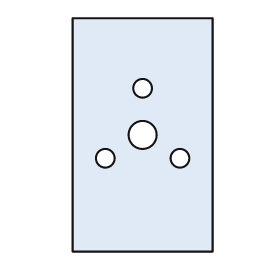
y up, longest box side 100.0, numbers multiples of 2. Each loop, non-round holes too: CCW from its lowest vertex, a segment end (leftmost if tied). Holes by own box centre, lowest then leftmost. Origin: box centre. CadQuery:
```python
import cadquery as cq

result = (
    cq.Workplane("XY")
    .moveTo(-30.0, -50.0)
    .lineTo(30.0, -50.0)
    .lineTo(30.0, 50.0)
    .lineTo(-30.0, 50.0)
    .close()
    .moveTo(-16.0, -10.0)
    .circle(4.0)
    .moveTo(16.0, -10.0)
    .circle(4.0)
    .moveTo(0.0, 0.0)
    .circle(6.0)
    .moveTo(0.0, 20.0)
    .circle(4.0)
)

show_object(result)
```